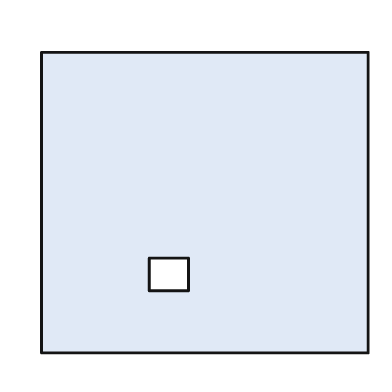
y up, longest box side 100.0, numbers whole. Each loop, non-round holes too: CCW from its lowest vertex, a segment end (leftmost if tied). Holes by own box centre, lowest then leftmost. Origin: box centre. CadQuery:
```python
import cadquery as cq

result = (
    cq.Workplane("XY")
    .moveTo(-50.0, -46.0)
    .lineTo(50.0, -46.0)
    .lineTo(50.0, 46.0)
    .lineTo(-50.0, 46.0)
    .close()
    .moveTo(-17.0, -27.0)
    .lineTo(-5.0, -27.0)
    .lineTo(-5.0, -17.0)
    .lineTo(-17.0, -17.0)
    .close()
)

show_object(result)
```